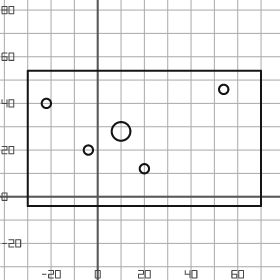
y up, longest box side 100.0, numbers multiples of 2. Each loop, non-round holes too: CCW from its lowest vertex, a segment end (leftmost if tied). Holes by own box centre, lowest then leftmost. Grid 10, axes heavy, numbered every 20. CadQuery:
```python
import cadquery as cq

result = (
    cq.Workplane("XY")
    .moveTo(-30.0, -4.0)
    .lineTo(70.0, -4.0)
    .lineTo(70.0, 54.0)
    .lineTo(-30.0, 54.0)
    .close()
    .moveTo(20.0, 12.0)
    .circle(2.0)
    .moveTo(-4.0, 20.0)
    .circle(2.0)
    .moveTo(10.0, 28.0)
    .circle(4.0)
    .moveTo(-22.0, 40.0)
    .circle(2.0)
    .moveTo(54.0, 46.0)
    .circle(2.0)
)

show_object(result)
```